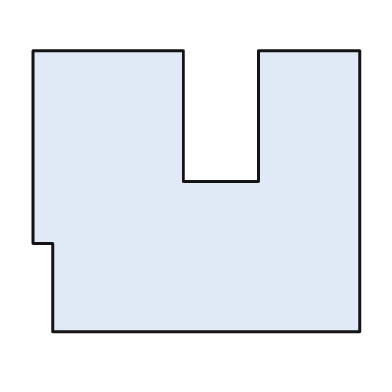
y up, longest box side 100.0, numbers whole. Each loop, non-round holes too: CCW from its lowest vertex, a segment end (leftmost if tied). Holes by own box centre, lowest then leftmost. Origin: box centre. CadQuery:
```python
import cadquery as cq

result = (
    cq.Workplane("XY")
    .moveTo(-44.0, -43.0)
    .lineTo(50.0, -43.0)
    .lineTo(50.0, 43.0)
    .lineTo(19.0, 43.0)
    .lineTo(19.0, 3.0)
    .lineTo(-4.0, 3.0)
    .lineTo(-4.0, 43.0)
    .lineTo(-50.0, 43.0)
    .lineTo(-50.0, -16.0)
    .lineTo(-44.0, -16.0)
    .close()
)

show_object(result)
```